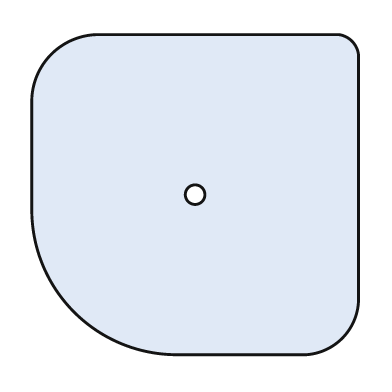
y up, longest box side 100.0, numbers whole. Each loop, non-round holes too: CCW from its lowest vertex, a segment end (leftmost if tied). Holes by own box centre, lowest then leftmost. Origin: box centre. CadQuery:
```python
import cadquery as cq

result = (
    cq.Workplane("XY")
    .moveTo(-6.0, -49.0)
    .lineTo(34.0, -49.0)
    .threePointArc((45.0, -44.0), (50.0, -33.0))
    .lineTo(50.0, 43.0)
    .threePointArc((48.0, 47.0), (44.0, 49.0))
    .lineTo(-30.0, 49.0)
    .threePointArc((-44.0, 43.0), (-50.0, 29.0))
    .lineTo(-50.0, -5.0)
    .threePointArc((-37.0, -36.0), (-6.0, -49.0))
    .close()
    .moveTo(0.0, 0.0)
    .circle(3.0)
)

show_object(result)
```